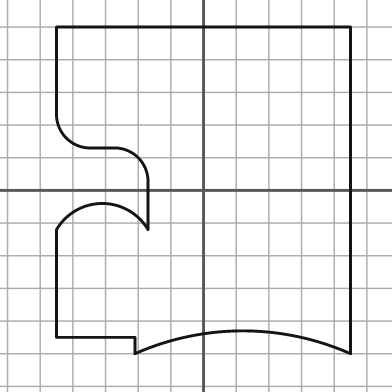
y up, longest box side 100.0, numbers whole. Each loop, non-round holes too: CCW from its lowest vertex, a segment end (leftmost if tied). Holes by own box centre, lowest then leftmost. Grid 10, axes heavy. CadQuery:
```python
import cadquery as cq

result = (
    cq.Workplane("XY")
    .moveTo(-21.0, -50.0)
    .threePointArc((12.0, -43.0), (45.0, -50.0))
    .lineTo(45.0, 50.0)
    .lineTo(-45.0, 50.0)
    .lineTo(-45.0, 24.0)
    .threePointArc((-42.0, 16.0), (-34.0, 13.0))
    .lineTo(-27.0, 13.0)
    .threePointArc((-20.0, 10.0), (-17.0, 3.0))
    .lineTo(-17.0, -12.0)
    .threePointArc((-31.0, -4.0), (-45.0, -12.0))
    .lineTo(-45.0, -45.0)
    .lineTo(-21.0, -45.0)
    .close()
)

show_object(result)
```